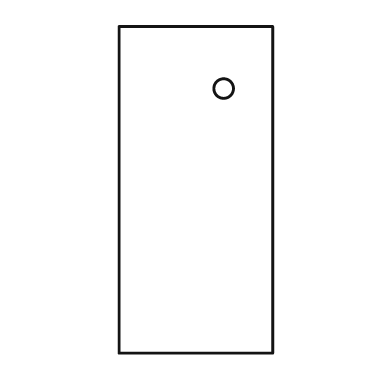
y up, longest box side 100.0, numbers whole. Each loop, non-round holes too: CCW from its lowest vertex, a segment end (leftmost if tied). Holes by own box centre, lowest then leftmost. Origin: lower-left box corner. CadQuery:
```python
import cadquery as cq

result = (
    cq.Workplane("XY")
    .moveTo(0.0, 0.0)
    .lineTo(47.0, 0.0)
    .lineTo(47.0, 100.0)
    .lineTo(0.0, 100.0)
    .close()
    .moveTo(32.0, 81.0)
    .circle(3.0)
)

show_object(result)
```